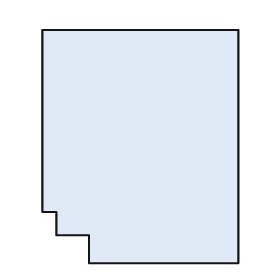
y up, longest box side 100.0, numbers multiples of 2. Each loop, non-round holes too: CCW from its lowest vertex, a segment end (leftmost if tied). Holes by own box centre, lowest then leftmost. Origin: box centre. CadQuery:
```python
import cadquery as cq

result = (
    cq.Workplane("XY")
    .moveTo(-22.0, -50.0)
    .lineTo(42.0, -50.0)
    .lineTo(42.0, 50.0)
    .lineTo(-42.0, 50.0)
    .lineTo(-42.0, -28.0)
    .lineTo(-36.0, -28.0)
    .lineTo(-36.0, -38.0)
    .lineTo(-22.0, -38.0)
    .close()
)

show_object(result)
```